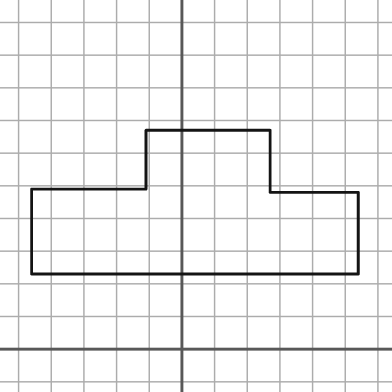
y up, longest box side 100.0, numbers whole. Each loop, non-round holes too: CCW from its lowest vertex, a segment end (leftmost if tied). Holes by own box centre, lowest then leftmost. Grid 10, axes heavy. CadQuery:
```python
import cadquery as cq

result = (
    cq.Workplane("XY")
    .moveTo(-46.0, 23.0)
    .lineTo(54.0, 23.0)
    .lineTo(54.0, 48.0)
    .lineTo(27.0, 48.0)
    .lineTo(27.0, 67.0)
    .lineTo(-11.0, 67.0)
    .lineTo(-11.0, 49.0)
    .lineTo(-46.0, 49.0)
    .close()
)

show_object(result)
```